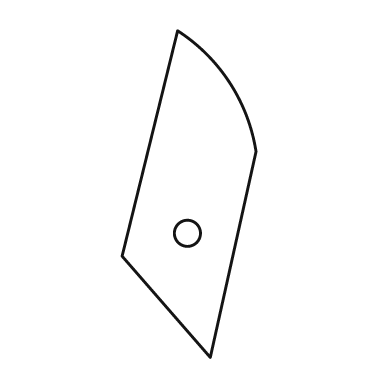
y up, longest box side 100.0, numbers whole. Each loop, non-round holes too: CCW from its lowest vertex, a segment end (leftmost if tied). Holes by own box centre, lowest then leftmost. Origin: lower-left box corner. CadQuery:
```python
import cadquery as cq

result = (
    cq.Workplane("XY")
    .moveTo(27.0, 0.0)
    .lineTo(41.0, 63.0)
    .threePointArc((33.0, 84.0), (17.0, 100.0))
    .lineTo(0.0, 31.0)
    .close()
    .moveTo(20.0, 38.0)
    .circle(4.0)
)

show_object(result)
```